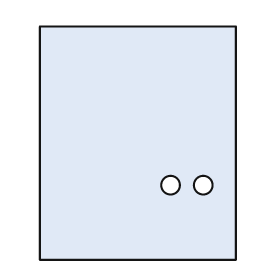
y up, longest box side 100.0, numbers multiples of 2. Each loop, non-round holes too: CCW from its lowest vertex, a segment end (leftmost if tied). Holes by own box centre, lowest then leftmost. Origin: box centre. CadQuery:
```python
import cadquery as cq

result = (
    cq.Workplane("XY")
    .moveTo(-42.0, -50.0)
    .lineTo(42.0, -50.0)
    .lineTo(42.0, 50.0)
    .lineTo(-42.0, 50.0)
    .close()
    .moveTo(14.0, -18.0)
    .circle(4.0)
    .moveTo(28.0, -18.0)
    .circle(4.0)
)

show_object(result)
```